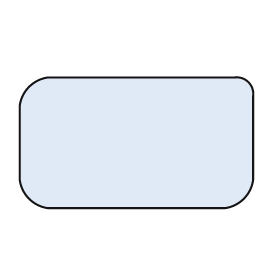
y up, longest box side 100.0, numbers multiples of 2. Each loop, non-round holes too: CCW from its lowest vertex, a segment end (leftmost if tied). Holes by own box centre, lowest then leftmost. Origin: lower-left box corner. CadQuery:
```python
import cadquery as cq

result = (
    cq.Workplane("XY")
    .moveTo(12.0, 0.0)
    .lineTo(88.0, 0.0)
    .threePointArc((96.0, 4.0), (100.0, 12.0))
    .lineTo(100.0, 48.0)
    .threePointArc((98.0, 54.0), (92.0, 56.0))
    .lineTo(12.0, 56.0)
    .threePointArc((4.0, 52.0), (0.0, 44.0))
    .lineTo(0.0, 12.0)
    .threePointArc((4.0, 4.0), (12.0, 0.0))
    .close()
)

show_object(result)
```